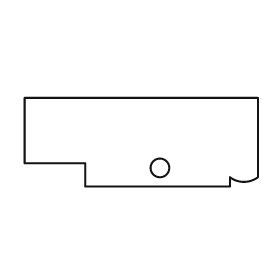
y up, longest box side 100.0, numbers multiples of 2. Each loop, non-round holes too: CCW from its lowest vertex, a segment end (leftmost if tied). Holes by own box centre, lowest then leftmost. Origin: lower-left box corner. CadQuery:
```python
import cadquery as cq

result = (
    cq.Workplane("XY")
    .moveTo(26.0, 0.0)
    .lineTo(88.0, 0.0)
    .lineTo(88.0, 4.0)
    .threePointArc((94.0, 2.0), (100.0, 4.0))
    .lineTo(100.0, 38.0)
    .lineTo(0.0, 38.0)
    .lineTo(0.0, 10.0)
    .lineTo(26.0, 10.0)
    .close()
    .moveTo(58.0, 8.0)
    .circle(4.0)
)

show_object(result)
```